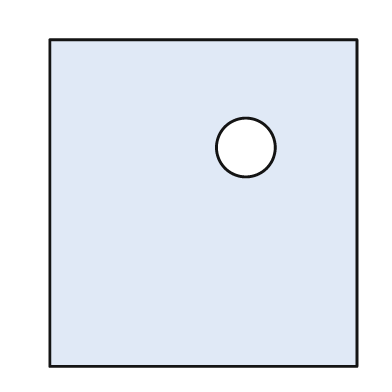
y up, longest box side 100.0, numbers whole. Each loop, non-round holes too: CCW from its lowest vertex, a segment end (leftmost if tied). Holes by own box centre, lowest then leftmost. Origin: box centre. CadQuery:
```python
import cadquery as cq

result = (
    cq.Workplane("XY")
    .moveTo(-47.0, -50.0)
    .lineTo(47.0, -50.0)
    .lineTo(47.0, 50.0)
    .lineTo(-47.0, 50.0)
    .close()
    .moveTo(13.0, 17.0)
    .circle(9.0)
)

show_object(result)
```